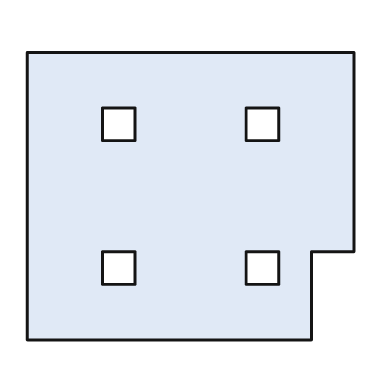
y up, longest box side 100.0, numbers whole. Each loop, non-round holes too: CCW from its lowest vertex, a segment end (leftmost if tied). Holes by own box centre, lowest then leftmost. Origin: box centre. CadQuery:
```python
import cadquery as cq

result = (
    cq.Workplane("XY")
    .moveTo(-50.0, -44.0)
    .lineTo(37.0, -44.0)
    .lineTo(37.0, -17.0)
    .lineTo(50.0, -17.0)
    .lineTo(50.0, 44.0)
    .lineTo(-50.0, 44.0)
    .close()
    .moveTo(-27.0, -27.0)
    .lineTo(-17.0, -27.0)
    .lineTo(-17.0, -17.0)
    .lineTo(-27.0, -17.0)
    .close()
    .moveTo(17.0, -27.0)
    .lineTo(27.0, -27.0)
    .lineTo(27.0, -17.0)
    .lineTo(17.0, -17.0)
    .close()
    .moveTo(-27.0, 17.0)
    .lineTo(-17.0, 17.0)
    .lineTo(-17.0, 27.0)
    .lineTo(-27.0, 27.0)
    .close()
    .moveTo(17.0, 17.0)
    .lineTo(27.0, 17.0)
    .lineTo(27.0, 27.0)
    .lineTo(17.0, 27.0)
    .close()
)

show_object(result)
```